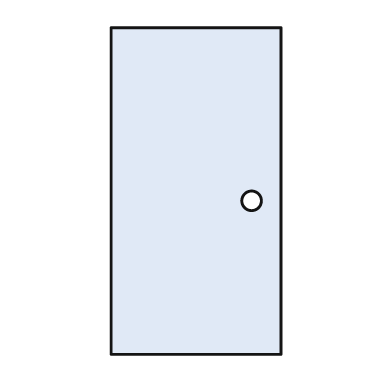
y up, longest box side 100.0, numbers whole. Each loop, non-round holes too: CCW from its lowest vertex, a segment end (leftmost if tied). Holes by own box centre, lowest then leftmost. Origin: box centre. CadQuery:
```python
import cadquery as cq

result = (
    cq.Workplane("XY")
    .moveTo(-26.0, -50.0)
    .lineTo(26.0, -50.0)
    .lineTo(26.0, 50.0)
    .lineTo(-26.0, 50.0)
    .close()
    .moveTo(17.0, -3.0)
    .circle(3.0)
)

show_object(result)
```